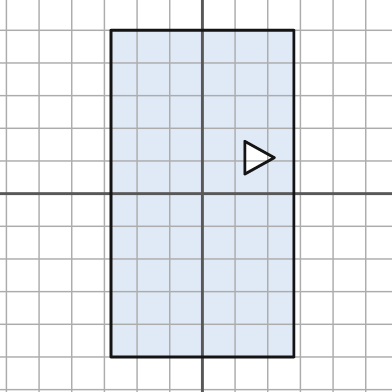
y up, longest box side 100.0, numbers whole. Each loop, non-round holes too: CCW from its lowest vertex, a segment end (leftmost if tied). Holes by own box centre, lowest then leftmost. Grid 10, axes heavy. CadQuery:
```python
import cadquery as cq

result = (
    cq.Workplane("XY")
    .moveTo(-28.0, -50.0)
    .lineTo(28.0, -50.0)
    .lineTo(28.0, 50.0)
    .lineTo(-28.0, 50.0)
    .close()
    .moveTo(13.0, 6.0)
    .lineTo(22.0, 11.0)
    .lineTo(13.0, 16.0)
    .close()
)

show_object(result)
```